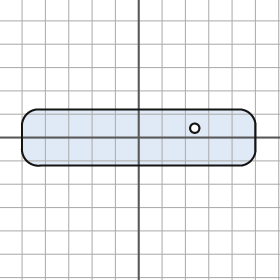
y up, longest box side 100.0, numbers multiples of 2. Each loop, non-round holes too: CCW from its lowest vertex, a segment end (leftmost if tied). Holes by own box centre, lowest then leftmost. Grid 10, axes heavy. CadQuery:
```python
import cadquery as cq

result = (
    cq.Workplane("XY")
    .moveTo(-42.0, -12.0)
    .lineTo(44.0, -12.0)
    .threePointArc((48.0, -10.0), (50.0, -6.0))
    .lineTo(50.0, 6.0)
    .threePointArc((48.0, 10.0), (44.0, 12.0))
    .lineTo(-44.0, 12.0)
    .threePointArc((-48.0, 10.0), (-50.0, 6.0))
    .lineTo(-50.0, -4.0)
    .threePointArc((-48.0, -10.0), (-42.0, -12.0))
    .close()
    .moveTo(24.0, 4.0)
    .circle(2.0)
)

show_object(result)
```